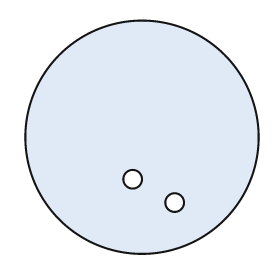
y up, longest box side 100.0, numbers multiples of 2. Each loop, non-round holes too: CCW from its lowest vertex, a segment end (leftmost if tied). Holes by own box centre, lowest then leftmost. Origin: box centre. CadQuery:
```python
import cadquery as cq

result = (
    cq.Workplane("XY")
    .moveTo(0.0, 0.0)
    .circle(50.0)
    .moveTo(14.0, -28.0)
    .circle(4.0)
    .moveTo(-4.0, -18.0)
    .circle(4.0)
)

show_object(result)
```